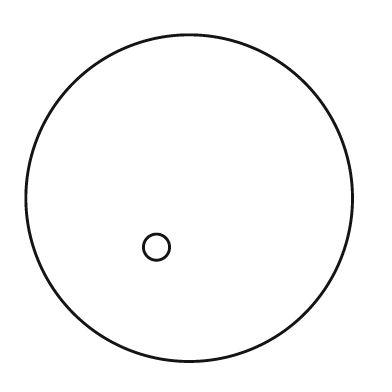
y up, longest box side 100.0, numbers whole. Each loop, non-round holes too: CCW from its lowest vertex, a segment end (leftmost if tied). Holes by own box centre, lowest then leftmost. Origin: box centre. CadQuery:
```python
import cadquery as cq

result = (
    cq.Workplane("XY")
    .moveTo(0.0, 0.0)
    .circle(50.0)
    .moveTo(-10.0, -15.0)
    .circle(4.0)
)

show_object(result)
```